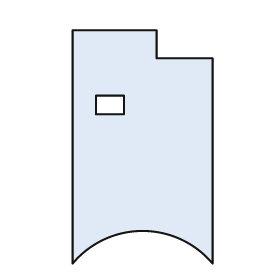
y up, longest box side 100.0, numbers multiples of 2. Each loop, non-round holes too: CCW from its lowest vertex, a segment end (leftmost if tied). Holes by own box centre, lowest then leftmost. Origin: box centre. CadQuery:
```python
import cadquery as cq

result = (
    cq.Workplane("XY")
    .moveTo(-30.0, -50.0)
    .threePointArc((0.0, -36.0), (30.0, -50.0))
    .lineTo(30.0, 38.0)
    .lineTo(6.0, 38.0)
    .lineTo(6.0, 50.0)
    .lineTo(-30.0, 50.0)
    .close()
    .moveTo(-20.0, 14.0)
    .lineTo(-8.0, 14.0)
    .lineTo(-8.0, 22.0)
    .lineTo(-20.0, 22.0)
    .close()
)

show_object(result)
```